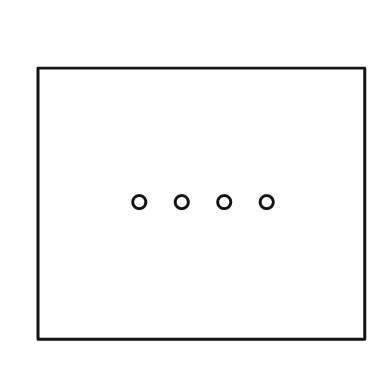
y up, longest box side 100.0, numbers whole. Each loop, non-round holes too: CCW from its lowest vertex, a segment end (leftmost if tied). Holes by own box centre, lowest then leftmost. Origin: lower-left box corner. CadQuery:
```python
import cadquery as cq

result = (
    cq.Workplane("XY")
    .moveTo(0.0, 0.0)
    .lineTo(100.0, 0.0)
    .lineTo(100.0, 83.0)
    .lineTo(0.0, 83.0)
    .close()
    .moveTo(31.0, 42.0)
    .circle(2.0)
    .moveTo(44.0, 42.0)
    .circle(2.0)
    .moveTo(57.0, 42.0)
    .circle(2.0)
    .moveTo(70.0, 42.0)
    .circle(2.0)
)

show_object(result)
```